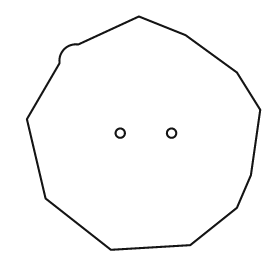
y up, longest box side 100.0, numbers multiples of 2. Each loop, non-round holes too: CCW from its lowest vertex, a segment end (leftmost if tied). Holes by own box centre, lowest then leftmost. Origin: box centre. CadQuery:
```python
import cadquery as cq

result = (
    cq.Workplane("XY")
    .moveTo(-14.0, -50.0)
    .lineTo(20.0, -48.0)
    .lineTo(40.0, -32.0)
    .lineTo(46.0, -18.0)
    .lineTo(50.0, 10.0)
    .lineTo(40.0, 26.0)
    .lineTo(18.0, 42.0)
    .lineTo(-2.0, 50.0)
    .lineTo(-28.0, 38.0)
    .threePointArc((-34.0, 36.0), (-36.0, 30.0))
    .lineTo(-50.0, 6.0)
    .lineTo(-42.0, -28.0)
    .close()
    .moveTo(-10.0, 0.0)
    .circle(2.0)
    .moveTo(12.0, 0.0)
    .circle(2.0)
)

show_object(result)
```